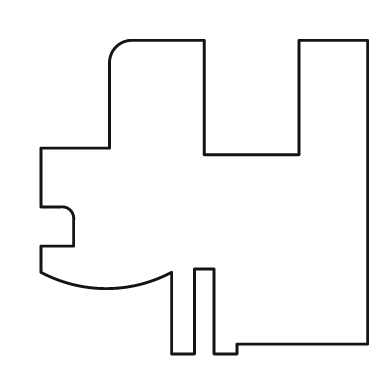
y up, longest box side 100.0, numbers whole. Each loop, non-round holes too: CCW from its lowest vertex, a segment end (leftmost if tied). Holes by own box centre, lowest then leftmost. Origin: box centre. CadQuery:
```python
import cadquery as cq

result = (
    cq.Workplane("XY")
    .moveTo(-10.0, -48.0)
    .lineTo(-3.0, -48.0)
    .lineTo(-3.0, -22.0)
    .lineTo(3.0, -22.0)
    .lineTo(3.0, -48.0)
    .lineTo(10.0, -48.0)
    .lineTo(10.0, -45.0)
    .lineTo(50.0, -45.0)
    .lineTo(50.0, 48.0)
    .lineTo(29.0, 48.0)
    .lineTo(29.0, 13.0)
    .lineTo(0.0, 13.0)
    .lineTo(0.0, 48.0)
    .lineTo(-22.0, 48.0)
    .threePointArc((-27.0, 46.0), (-29.0, 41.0))
    .lineTo(-29.0, 15.0)
    .lineTo(-50.0, 15.0)
    .lineTo(-50.0, -3.0)
    .lineTo(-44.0, -3.0)
    .threePointArc((-41.0, -4.0), (-40.0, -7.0))
    .lineTo(-40.0, -15.0)
    .lineTo(-50.0, -15.0)
    .lineTo(-50.0, -23.0)
    .threePointArc((-30.0, -28.0), (-10.0, -23.0))
    .close()
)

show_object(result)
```